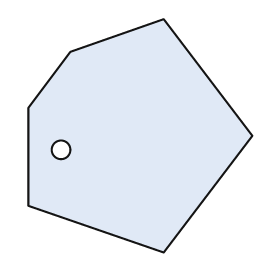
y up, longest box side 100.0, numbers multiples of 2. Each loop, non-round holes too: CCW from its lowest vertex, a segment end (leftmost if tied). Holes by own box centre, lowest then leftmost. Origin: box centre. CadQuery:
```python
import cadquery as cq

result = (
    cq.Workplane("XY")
    .moveTo(10.0, -50.0)
    .lineTo(48.0, 0.0)
    .lineTo(10.0, 50.0)
    .lineTo(-30.0, 36.0)
    .lineTo(-48.0, 12.0)
    .lineTo(-48.0, -30.0)
    .close()
    .moveTo(-34.0, -6.0)
    .circle(4.0)
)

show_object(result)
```